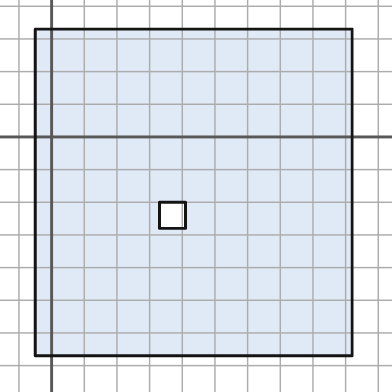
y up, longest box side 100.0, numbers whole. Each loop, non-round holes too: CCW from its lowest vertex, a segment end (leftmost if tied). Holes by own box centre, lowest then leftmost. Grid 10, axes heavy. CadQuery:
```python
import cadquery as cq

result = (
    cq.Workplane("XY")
    .moveTo(-5.0, -67.0)
    .lineTo(92.0, -67.0)
    .lineTo(92.0, 33.0)
    .lineTo(-5.0, 33.0)
    .close()
    .moveTo(33.0, -28.0)
    .lineTo(41.0, -28.0)
    .lineTo(41.0, -20.0)
    .lineTo(33.0, -20.0)
    .close()
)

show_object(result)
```